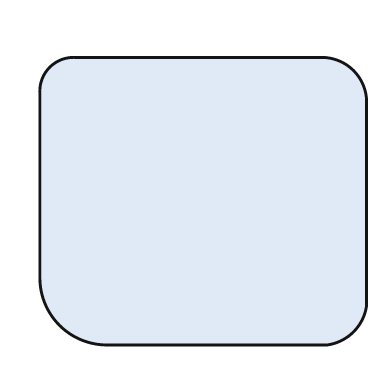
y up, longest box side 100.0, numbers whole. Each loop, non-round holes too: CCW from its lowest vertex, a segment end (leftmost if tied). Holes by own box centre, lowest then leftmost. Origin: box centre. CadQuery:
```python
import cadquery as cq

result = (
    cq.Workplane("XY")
    .moveTo(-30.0, -44.0)
    .lineTo(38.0, -44.0)
    .threePointArc((46.0, -40.0), (50.0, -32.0))
    .lineTo(50.0, 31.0)
    .threePointArc((46.0, 40.0), (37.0, 44.0))
    .lineTo(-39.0, 44.0)
    .threePointArc((-47.0, 41.0), (-50.0, 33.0))
    .lineTo(-50.0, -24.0)
    .threePointArc((-44.0, -38.0), (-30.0, -44.0))
    .close()
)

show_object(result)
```